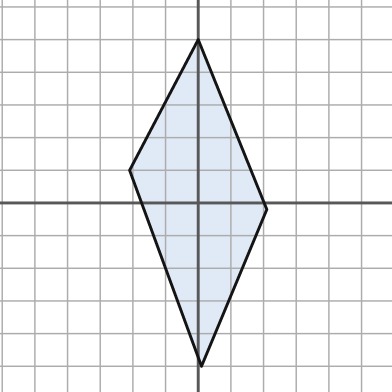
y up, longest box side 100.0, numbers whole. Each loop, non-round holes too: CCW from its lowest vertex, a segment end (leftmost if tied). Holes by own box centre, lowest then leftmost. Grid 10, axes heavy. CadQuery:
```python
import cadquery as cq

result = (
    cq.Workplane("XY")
    .moveTo(1.0, -50.0)
    .lineTo(21.0, -2.0)
    .lineTo(0.0, 50.0)
    .lineTo(-21.0, 10.0)
    .close()
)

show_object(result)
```